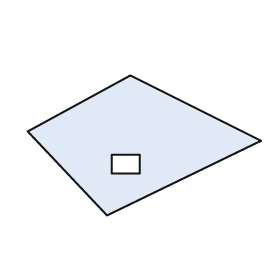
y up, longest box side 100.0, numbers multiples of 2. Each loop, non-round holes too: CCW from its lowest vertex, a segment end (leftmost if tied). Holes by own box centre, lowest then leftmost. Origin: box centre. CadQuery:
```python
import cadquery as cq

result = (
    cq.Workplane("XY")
    .moveTo(-16.0, -30.0)
    .lineTo(50.0, 2.0)
    .lineTo(-6.0, 30.0)
    .lineTo(-50.0, 6.0)
    .close()
    .moveTo(-14.0, -12.0)
    .lineTo(-2.0, -12.0)
    .lineTo(-2.0, -4.0)
    .lineTo(-14.0, -4.0)
    .close()
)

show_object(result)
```